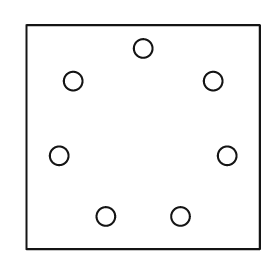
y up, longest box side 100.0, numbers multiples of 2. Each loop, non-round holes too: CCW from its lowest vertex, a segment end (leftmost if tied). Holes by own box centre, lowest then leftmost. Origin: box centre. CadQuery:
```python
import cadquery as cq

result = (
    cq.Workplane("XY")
    .moveTo(-50.0, -48.0)
    .lineTo(50.0, -48.0)
    .lineTo(50.0, 48.0)
    .lineTo(-50.0, 48.0)
    .close()
    .moveTo(-16.0, -34.0)
    .circle(4.0)
    .moveTo(16.0, -34.0)
    .circle(4.0)
    .moveTo(-36.0, -8.0)
    .circle(4.0)
    .moveTo(36.0, -8.0)
    .circle(4.0)
    .moveTo(-30.0, 24.0)
    .circle(4.0)
    .moveTo(30.0, 24.0)
    .circle(4.0)
    .moveTo(0.0, 38.0)
    .circle(4.0)
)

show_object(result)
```